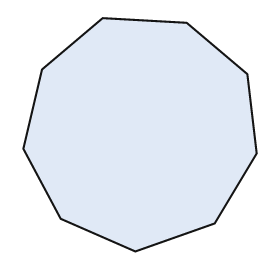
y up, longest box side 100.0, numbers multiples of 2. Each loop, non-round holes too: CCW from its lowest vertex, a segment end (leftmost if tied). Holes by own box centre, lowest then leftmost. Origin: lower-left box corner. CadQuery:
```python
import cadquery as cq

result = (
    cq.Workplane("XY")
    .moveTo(48.0, 0.0)
    .lineTo(82.0, 12.0)
    .lineTo(100.0, 42.0)
    .lineTo(96.0, 76.0)
    .lineTo(70.0, 98.0)
    .lineTo(34.0, 100.0)
    .lineTo(8.0, 78.0)
    .lineTo(0.0, 44.0)
    .lineTo(16.0, 14.0)
    .close()
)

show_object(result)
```